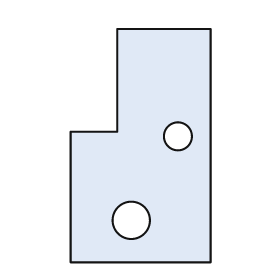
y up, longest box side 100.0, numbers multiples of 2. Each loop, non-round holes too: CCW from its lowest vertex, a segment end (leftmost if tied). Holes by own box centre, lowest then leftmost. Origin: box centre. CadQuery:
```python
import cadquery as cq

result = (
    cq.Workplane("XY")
    .moveTo(-30.0, -50.0)
    .lineTo(30.0, -50.0)
    .lineTo(30.0, 50.0)
    .lineTo(-10.0, 50.0)
    .lineTo(-10.0, 6.0)
    .lineTo(-30.0, 6.0)
    .close()
    .moveTo(-4.0, -32.0)
    .circle(8.0)
    .moveTo(16.0, 4.0)
    .circle(6.0)
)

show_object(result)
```